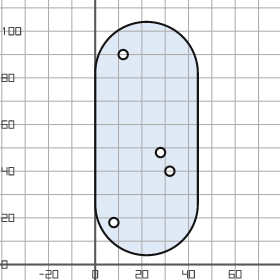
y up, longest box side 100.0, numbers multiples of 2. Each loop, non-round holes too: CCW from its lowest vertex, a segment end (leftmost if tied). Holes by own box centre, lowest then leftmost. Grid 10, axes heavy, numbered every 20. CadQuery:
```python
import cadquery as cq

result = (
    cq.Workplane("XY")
    .moveTo(0.0, 26.0)
    .threePointArc((22.0, 4.0), (44.0, 26.0))
    .lineTo(44.0, 82.0)
    .threePointArc((22.0, 104.0), (0.0, 82.0))
    .close()
    .moveTo(8.0, 18.0)
    .circle(2.0)
    .moveTo(32.0, 40.0)
    .circle(2.0)
    .moveTo(28.0, 48.0)
    .circle(2.0)
    .moveTo(12.0, 90.0)
    .circle(2.0)
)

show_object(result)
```